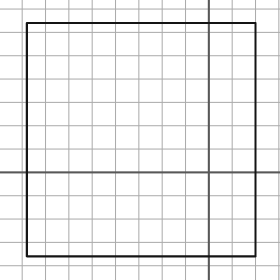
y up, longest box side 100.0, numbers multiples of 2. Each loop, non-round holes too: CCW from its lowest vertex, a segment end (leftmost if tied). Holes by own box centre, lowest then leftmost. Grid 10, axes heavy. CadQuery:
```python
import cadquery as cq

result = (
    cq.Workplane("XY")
    .moveTo(-78.0, -36.0)
    .lineTo(20.0, -36.0)
    .lineTo(20.0, 64.0)
    .lineTo(-78.0, 64.0)
    .close()
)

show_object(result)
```